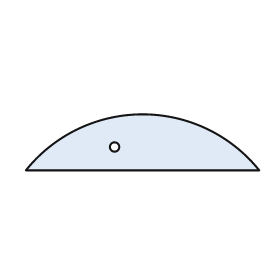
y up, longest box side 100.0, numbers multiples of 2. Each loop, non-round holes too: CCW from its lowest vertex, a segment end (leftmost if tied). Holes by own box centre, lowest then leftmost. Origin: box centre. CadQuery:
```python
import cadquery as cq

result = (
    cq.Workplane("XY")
    .moveTo(-50.0, -12.0)
    .lineTo(50.0, -12.0)
    .threePointArc((0.0, 12.0), (-50.0, -12.0))
    .close()
    .moveTo(-12.0, -2.0)
    .circle(2.0)
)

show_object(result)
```